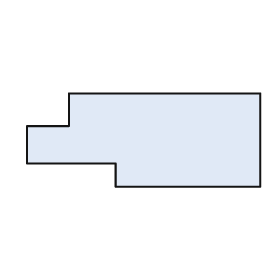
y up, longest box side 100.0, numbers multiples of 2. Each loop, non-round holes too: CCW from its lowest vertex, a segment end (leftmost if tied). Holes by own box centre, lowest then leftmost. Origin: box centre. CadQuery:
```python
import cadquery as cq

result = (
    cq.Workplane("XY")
    .moveTo(-12.0, -20.0)
    .lineTo(50.0, -20.0)
    .lineTo(50.0, 20.0)
    .lineTo(-32.0, 20.0)
    .lineTo(-32.0, 6.0)
    .lineTo(-50.0, 6.0)
    .lineTo(-50.0, -10.0)
    .lineTo(-12.0, -10.0)
    .close()
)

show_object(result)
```